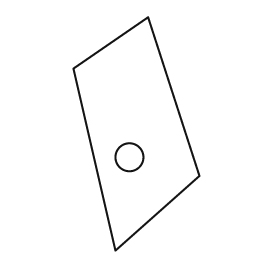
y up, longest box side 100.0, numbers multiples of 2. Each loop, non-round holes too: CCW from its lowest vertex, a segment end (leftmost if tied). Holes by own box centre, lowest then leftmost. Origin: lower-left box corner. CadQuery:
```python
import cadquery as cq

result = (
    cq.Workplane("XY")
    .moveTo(18.0, 0.0)
    .lineTo(54.0, 32.0)
    .lineTo(32.0, 100.0)
    .lineTo(0.0, 78.0)
    .close()
    .moveTo(24.0, 40.0)
    .circle(6.0)
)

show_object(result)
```